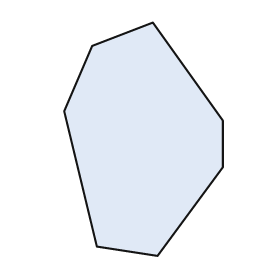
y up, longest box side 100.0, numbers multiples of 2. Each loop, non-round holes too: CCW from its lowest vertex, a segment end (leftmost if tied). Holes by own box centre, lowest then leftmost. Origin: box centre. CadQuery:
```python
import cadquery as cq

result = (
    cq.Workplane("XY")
    .moveTo(6.0, -50.0)
    .lineTo(34.0, -12.0)
    .lineTo(34.0, 8.0)
    .lineTo(4.0, 50.0)
    .lineTo(-22.0, 40.0)
    .lineTo(-34.0, 12.0)
    .lineTo(-20.0, -46.0)
    .close()
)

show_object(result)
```